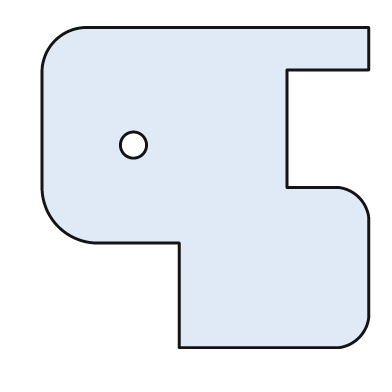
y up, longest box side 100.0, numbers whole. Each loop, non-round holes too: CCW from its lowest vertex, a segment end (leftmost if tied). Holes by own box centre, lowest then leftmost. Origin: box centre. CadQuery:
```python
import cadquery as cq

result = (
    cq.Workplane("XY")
    .moveTo(-8.0, -49.0)
    .lineTo(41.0, -49.0)
    .threePointArc((47.0, -46.0), (50.0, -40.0))
    .lineTo(50.0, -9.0)
    .threePointArc((47.0, -3.0), (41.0, 0.0))
    .lineTo(25.0, 0.0)
    .lineTo(25.0, 36.0)
    .lineTo(50.0, 36.0)
    .lineTo(50.0, 49.0)
    .lineTo(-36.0, 49.0)
    .threePointArc((-46.0, 45.0), (-50.0, 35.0))
    .lineTo(-50.0, 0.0)
    .threePointArc((-45.0, -12.0), (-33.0, -17.0))
    .lineTo(-8.0, -17.0)
    .close()
    .moveTo(-22.0, 13.0)
    .circle(4.0)
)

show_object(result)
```